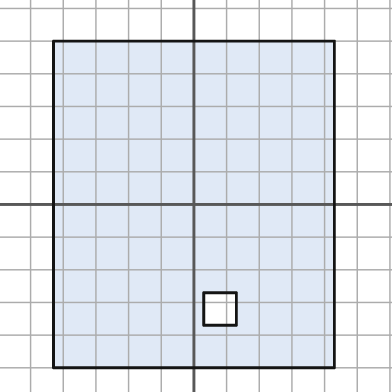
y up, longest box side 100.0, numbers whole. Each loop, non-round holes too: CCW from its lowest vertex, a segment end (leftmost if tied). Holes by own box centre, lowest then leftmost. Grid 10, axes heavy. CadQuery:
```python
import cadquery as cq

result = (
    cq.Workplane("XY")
    .moveTo(-43.0, -50.0)
    .lineTo(43.0, -50.0)
    .lineTo(43.0, 50.0)
    .lineTo(-43.0, 50.0)
    .close()
    .moveTo(3.0, -37.0)
    .lineTo(13.0, -37.0)
    .lineTo(13.0, -27.0)
    .lineTo(3.0, -27.0)
    .close()
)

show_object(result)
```